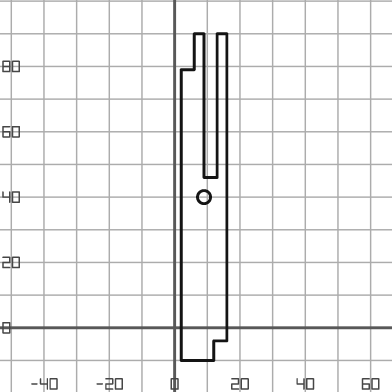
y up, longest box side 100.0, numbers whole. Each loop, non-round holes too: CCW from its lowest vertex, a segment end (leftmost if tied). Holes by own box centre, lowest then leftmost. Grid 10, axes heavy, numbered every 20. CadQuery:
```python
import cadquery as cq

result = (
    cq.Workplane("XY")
    .moveTo(2.0, -10.0)
    .lineTo(12.0, -10.0)
    .lineTo(12.0, -4.0)
    .lineTo(16.0, -4.0)
    .lineTo(16.0, 90.0)
    .lineTo(13.0, 90.0)
    .lineTo(13.0, 46.0)
    .lineTo(9.0, 46.0)
    .lineTo(9.0, 90.0)
    .lineTo(6.0, 90.0)
    .lineTo(6.0, 79.0)
    .lineTo(2.0, 79.0)
    .close()
    .moveTo(9.0, 40.0)
    .circle(2.0)
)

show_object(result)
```